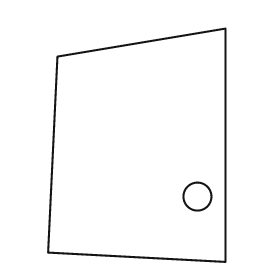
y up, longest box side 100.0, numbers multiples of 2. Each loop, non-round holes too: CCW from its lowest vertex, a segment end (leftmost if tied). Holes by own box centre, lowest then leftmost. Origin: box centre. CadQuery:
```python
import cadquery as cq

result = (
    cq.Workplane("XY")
    .moveTo(38.0, -50.0)
    .lineTo(38.0, 50.0)
    .lineTo(-34.0, 38.0)
    .lineTo(-38.0, -46.0)
    .close()
    .moveTo(26.0, -22.0)
    .circle(6.0)
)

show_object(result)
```